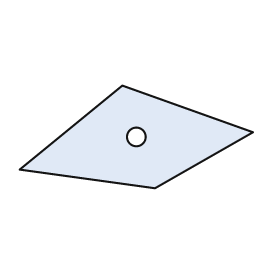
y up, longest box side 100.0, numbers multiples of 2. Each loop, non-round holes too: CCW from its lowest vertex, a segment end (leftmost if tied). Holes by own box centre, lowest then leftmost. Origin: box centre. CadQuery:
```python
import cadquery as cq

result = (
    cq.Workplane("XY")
    .moveTo(8.0, -22.0)
    .lineTo(50.0, 2.0)
    .lineTo(-6.0, 22.0)
    .lineTo(-50.0, -14.0)
    .close()
    .moveTo(0.0, 0.0)
    .circle(4.0)
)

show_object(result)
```